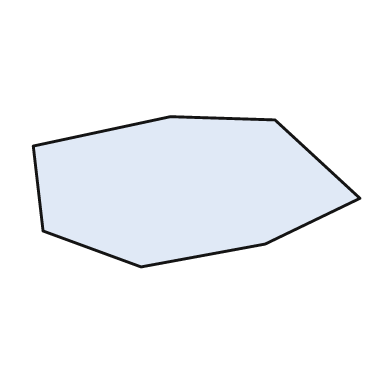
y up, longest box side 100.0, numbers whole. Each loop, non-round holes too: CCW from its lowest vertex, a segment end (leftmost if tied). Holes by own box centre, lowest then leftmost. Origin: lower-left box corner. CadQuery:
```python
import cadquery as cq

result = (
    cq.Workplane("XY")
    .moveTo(33.0, 0.0)
    .lineTo(71.0, 7.0)
    .lineTo(100.0, 21.0)
    .lineTo(74.0, 45.0)
    .lineTo(42.0, 46.0)
    .lineTo(0.0, 37.0)
    .lineTo(3.0, 11.0)
    .close()
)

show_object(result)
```